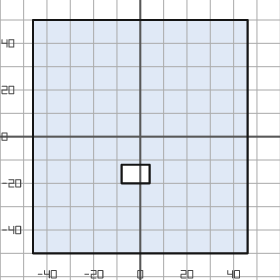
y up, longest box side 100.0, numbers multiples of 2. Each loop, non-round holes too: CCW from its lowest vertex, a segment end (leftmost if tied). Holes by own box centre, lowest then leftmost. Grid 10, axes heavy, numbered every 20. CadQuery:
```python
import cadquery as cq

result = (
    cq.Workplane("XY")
    .moveTo(-46.0, -50.0)
    .lineTo(46.0, -50.0)
    .lineTo(46.0, 50.0)
    .lineTo(-46.0, 50.0)
    .close()
    .moveTo(-8.0, -20.0)
    .lineTo(4.0, -20.0)
    .lineTo(4.0, -12.0)
    .lineTo(-8.0, -12.0)
    .close()
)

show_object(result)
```